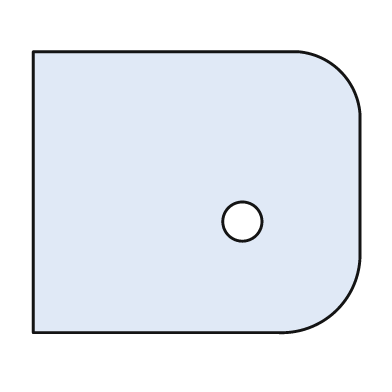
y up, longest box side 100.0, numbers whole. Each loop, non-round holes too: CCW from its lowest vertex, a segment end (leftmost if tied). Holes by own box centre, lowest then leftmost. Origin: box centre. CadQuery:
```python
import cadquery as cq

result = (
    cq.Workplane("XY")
    .moveTo(-50.0, -43.0)
    .lineTo(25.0, -43.0)
    .threePointArc((43.0, -36.0), (50.0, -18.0))
    .lineTo(50.0, 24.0)
    .threePointArc((44.0, 37.0), (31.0, 43.0))
    .lineTo(-50.0, 43.0)
    .close()
    .moveTo(14.0, -9.0)
    .circle(6.0)
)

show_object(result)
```